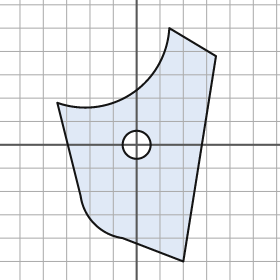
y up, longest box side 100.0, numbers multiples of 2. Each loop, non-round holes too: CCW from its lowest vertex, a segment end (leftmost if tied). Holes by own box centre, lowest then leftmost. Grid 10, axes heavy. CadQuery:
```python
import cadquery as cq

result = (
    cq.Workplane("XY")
    .moveTo(20.0, -50.0)
    .lineTo(34.0, 38.0)
    .lineTo(14.0, 50.0)
    .threePointArc((-2.0, 22.0), (-34.0, 18.0))
    .lineTo(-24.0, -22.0)
    .threePointArc((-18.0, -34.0), (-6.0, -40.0))
    .close()
    .moveTo(0.0, 0.0)
    .circle(6.0)
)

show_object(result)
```